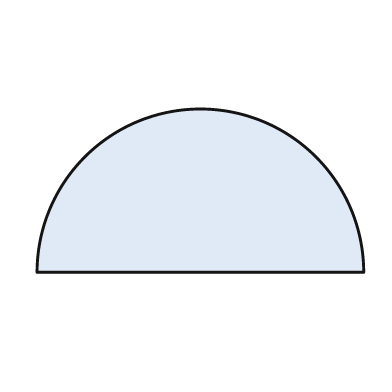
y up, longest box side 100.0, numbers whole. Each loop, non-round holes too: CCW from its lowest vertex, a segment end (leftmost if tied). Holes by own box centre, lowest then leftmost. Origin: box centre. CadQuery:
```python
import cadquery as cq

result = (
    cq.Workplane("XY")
    .moveTo(-50.0, -25.0)
    .lineTo(50.0, -25.0)
    .threePointArc((0.0, 25.0), (-50.0, -25.0))
    .close()
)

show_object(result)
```